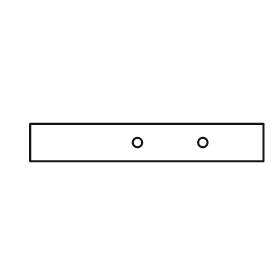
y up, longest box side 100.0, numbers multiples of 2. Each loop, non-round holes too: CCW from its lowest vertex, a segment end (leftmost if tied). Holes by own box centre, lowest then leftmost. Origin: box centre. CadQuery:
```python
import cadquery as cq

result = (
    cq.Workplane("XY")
    .moveTo(-50.0, -8.0)
    .lineTo(50.0, -8.0)
    .lineTo(50.0, 8.0)
    .lineTo(-50.0, 8.0)
    .close()
    .moveTo(-4.0, 0.0)
    .circle(2.0)
    .moveTo(24.0, 0.0)
    .circle(2.0)
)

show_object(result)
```